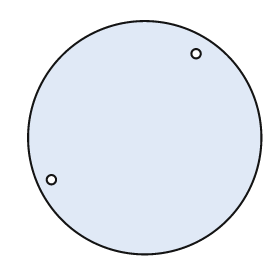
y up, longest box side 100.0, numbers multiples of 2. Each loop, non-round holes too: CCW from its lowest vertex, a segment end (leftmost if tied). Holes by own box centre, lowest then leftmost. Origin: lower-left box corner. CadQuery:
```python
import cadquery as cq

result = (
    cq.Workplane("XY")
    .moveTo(50.0, 50.0)
    .circle(50.0)
    .moveTo(10.0, 32.0)
    .circle(2.0)
    .moveTo(72.0, 86.0)
    .circle(2.0)
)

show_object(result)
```